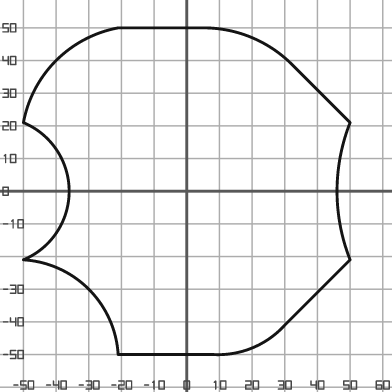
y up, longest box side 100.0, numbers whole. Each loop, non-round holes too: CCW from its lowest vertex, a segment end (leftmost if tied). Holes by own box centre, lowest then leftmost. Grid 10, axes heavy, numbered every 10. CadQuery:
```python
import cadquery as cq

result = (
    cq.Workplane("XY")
    .moveTo(-21.0, -50.0)
    .lineTo(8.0, -50.0)
    .threePointArc((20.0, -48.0), (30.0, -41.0))
    .lineTo(50.0, -21.0)
    .threePointArc((46.0, 0.0), (50.0, 21.0))
    .lineTo(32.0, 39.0)
    .threePointArc((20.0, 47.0), (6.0, 50.0))
    .lineTo(-21.0, 50.0)
    .threePointArc((-40.0, 40.0), (-50.0, 21.0))
    .threePointArc((-36.0, 0.0), (-50.0, -21.0))
    .threePointArc((-30.0, -30.0), (-21.0, -50.0))
    .close()
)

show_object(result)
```